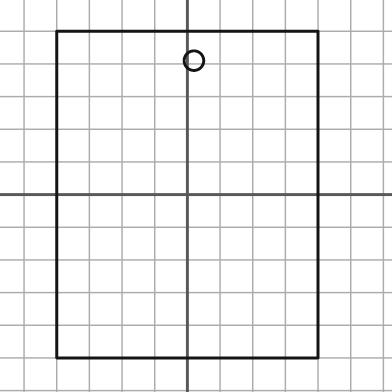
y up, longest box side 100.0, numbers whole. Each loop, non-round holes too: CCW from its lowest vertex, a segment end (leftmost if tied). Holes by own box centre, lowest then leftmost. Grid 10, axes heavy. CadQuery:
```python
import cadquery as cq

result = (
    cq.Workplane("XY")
    .moveTo(-40.0, -50.0)
    .lineTo(40.0, -50.0)
    .lineTo(40.0, 50.0)
    .lineTo(-40.0, 50.0)
    .close()
    .moveTo(2.0, 41.0)
    .circle(3.0)
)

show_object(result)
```